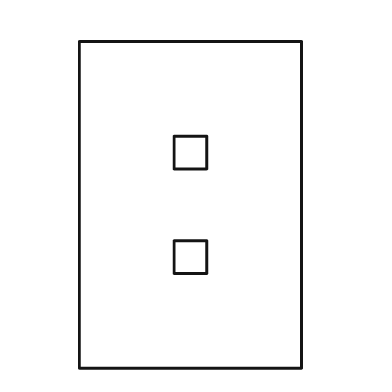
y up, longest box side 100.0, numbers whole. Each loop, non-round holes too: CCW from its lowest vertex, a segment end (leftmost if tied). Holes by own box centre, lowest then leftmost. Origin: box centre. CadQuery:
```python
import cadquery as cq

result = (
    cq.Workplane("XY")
    .moveTo(-34.0, -50.0)
    .lineTo(34.0, -50.0)
    .lineTo(34.0, 50.0)
    .lineTo(-34.0, 50.0)
    .close()
    .moveTo(-5.0, -21.0)
    .lineTo(5.0, -21.0)
    .lineTo(5.0, -11.0)
    .lineTo(-5.0, -11.0)
    .close()
    .moveTo(-5.0, 11.0)
    .lineTo(5.0, 11.0)
    .lineTo(5.0, 21.0)
    .lineTo(-5.0, 21.0)
    .close()
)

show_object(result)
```